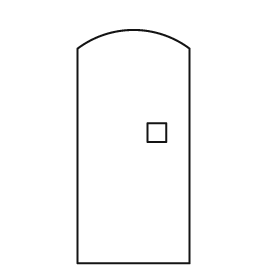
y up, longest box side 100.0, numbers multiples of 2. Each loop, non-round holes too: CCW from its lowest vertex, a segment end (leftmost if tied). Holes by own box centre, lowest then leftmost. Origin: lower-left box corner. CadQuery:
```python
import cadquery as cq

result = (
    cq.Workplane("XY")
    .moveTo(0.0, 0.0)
    .lineTo(48.0, 0.0)
    .lineTo(48.0, 92.0)
    .threePointArc((24.0, 100.0), (0.0, 92.0))
    .close()
    .moveTo(30.0, 52.0)
    .lineTo(38.0, 52.0)
    .lineTo(38.0, 60.0)
    .lineTo(30.0, 60.0)
    .close()
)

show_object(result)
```